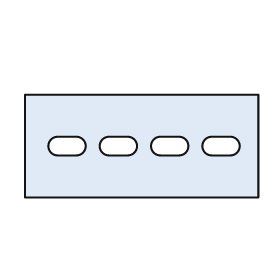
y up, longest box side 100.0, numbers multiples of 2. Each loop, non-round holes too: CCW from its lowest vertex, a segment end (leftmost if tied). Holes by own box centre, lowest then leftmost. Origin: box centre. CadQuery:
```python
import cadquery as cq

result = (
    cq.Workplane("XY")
    .moveTo(-50.0, -22.0)
    .lineTo(50.0, -22.0)
    .lineTo(50.0, 22.0)
    .lineTo(-50.0, 22.0)
    .close()
    .moveTo(-36.0, -4.0)
    .lineTo(-28.0, -4.0)
    .threePointArc((-24.0, 0.0), (-28.0, 4.0))
    .lineTo(-36.0, 4.0)
    .threePointArc((-40.0, 0.0), (-36.0, -4.0))
    .close()
    .moveTo(-14.0, -4.0)
    .lineTo(-6.0, -4.0)
    .threePointArc((-2.0, 0.0), (-6.0, 4.0))
    .lineTo(-14.0, 4.0)
    .threePointArc((-18.0, 0.0), (-14.0, -4.0))
    .close()
    .moveTo(8.0, -4.0)
    .lineTo(16.0, -4.0)
    .threePointArc((20.0, 0.0), (16.0, 4.0))
    .lineTo(8.0, 4.0)
    .threePointArc((4.0, 0.0), (8.0, -4.0))
    .close()
    .moveTo(30.0, -4.0)
    .lineTo(38.0, -4.0)
    .threePointArc((42.0, 0.0), (38.0, 4.0))
    .lineTo(30.0, 4.0)
    .threePointArc((26.0, 0.0), (30.0, -4.0))
    .close()
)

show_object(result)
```